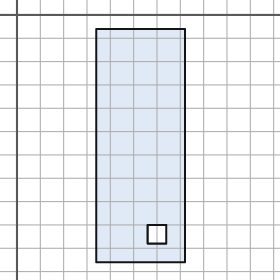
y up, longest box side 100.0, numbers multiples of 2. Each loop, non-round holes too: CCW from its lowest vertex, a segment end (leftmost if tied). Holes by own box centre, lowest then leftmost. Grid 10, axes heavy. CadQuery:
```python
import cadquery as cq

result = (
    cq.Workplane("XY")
    .moveTo(34.0, -106.0)
    .lineTo(72.0, -106.0)
    .lineTo(72.0, -6.0)
    .lineTo(34.0, -6.0)
    .close()
    .moveTo(56.0, -98.0)
    .lineTo(64.0, -98.0)
    .lineTo(64.0, -90.0)
    .lineTo(56.0, -90.0)
    .close()
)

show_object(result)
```